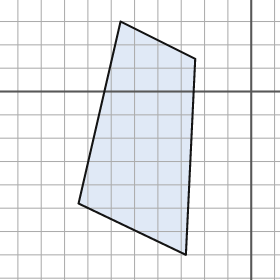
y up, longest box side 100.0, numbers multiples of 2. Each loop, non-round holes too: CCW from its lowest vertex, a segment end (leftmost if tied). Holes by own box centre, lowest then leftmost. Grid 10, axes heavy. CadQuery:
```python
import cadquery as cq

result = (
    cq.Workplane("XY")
    .moveTo(-28.0, -70.0)
    .lineTo(-24.0, 14.0)
    .lineTo(-56.0, 30.0)
    .lineTo(-74.0, -48.0)
    .close()
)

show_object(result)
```